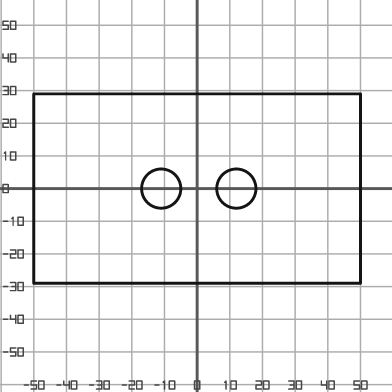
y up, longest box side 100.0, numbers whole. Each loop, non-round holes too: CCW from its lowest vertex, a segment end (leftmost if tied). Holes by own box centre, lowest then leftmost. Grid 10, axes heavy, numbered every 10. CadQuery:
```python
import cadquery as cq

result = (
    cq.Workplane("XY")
    .moveTo(-50.0, -29.0)
    .lineTo(50.0, -29.0)
    .lineTo(50.0, 29.0)
    .lineTo(-50.0, 29.0)
    .close()
    .moveTo(-11.0, 0.0)
    .circle(6.0)
    .moveTo(12.0, 0.0)
    .circle(6.0)
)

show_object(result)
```